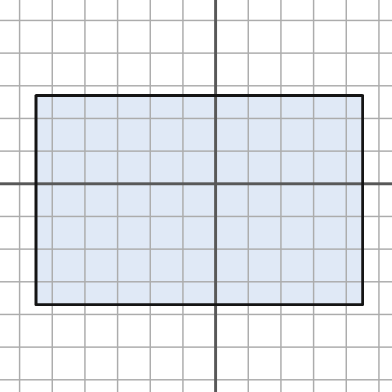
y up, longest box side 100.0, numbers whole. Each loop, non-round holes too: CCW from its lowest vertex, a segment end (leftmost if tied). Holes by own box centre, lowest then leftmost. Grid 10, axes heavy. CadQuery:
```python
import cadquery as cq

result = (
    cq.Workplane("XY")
    .moveTo(-55.0, -37.0)
    .lineTo(45.0, -37.0)
    .lineTo(45.0, 27.0)
    .lineTo(-55.0, 27.0)
    .close()
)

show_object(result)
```